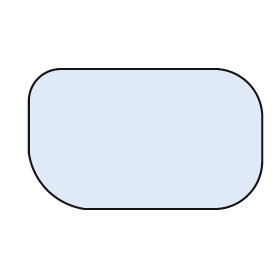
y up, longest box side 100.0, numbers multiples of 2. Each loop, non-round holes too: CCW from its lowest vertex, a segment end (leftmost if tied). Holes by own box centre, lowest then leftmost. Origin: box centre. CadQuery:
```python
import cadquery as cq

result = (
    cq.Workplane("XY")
    .moveTo(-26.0, -30.0)
    .lineTo(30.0, -30.0)
    .threePointArc((44.0, -24.0), (50.0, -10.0))
    .lineTo(50.0, 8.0)
    .threePointArc((44.0, 24.0), (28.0, 30.0))
    .lineTo(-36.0, 30.0)
    .threePointArc((-46.0, 26.0), (-50.0, 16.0))
    .lineTo(-50.0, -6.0)
    .threePointArc((-42.0, -22.0), (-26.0, -30.0))
    .close()
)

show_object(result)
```